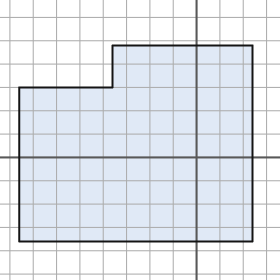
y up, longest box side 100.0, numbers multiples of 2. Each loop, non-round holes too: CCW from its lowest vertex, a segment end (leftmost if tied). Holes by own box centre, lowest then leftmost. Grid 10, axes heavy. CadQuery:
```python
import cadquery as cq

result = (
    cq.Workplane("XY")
    .moveTo(-76.0, -36.0)
    .lineTo(24.0, -36.0)
    .lineTo(24.0, 48.0)
    .lineTo(-36.0, 48.0)
    .lineTo(-36.0, 30.0)
    .lineTo(-76.0, 30.0)
    .close()
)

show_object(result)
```